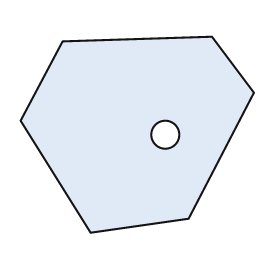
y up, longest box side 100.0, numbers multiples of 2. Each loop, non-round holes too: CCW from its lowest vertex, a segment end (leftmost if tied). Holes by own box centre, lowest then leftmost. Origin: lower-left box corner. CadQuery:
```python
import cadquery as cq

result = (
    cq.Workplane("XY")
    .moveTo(30.0, 0.0)
    .lineTo(72.0, 6.0)
    .lineTo(100.0, 60.0)
    .lineTo(82.0, 84.0)
    .lineTo(18.0, 82.0)
    .lineTo(0.0, 48.0)
    .close()
    .moveTo(62.0, 42.0)
    .circle(6.0)
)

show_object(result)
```